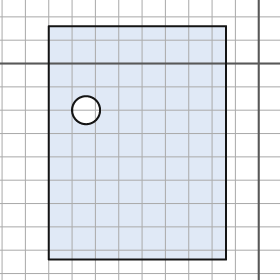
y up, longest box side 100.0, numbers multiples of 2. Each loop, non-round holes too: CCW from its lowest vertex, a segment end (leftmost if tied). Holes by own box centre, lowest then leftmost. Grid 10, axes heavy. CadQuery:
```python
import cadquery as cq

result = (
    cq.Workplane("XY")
    .moveTo(-90.0, -84.0)
    .lineTo(-14.0, -84.0)
    .lineTo(-14.0, 16.0)
    .lineTo(-90.0, 16.0)
    .close()
    .moveTo(-74.0, -20.0)
    .circle(6.0)
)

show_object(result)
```